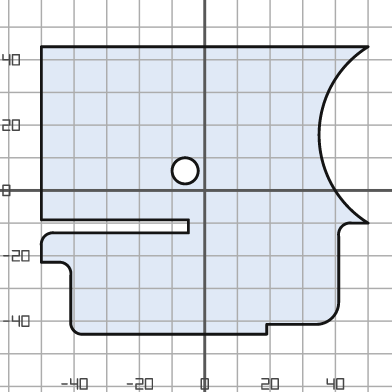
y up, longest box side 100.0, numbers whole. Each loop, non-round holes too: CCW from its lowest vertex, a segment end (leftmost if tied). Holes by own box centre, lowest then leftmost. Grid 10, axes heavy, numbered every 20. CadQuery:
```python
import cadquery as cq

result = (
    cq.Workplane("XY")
    .moveTo(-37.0, -44.0)
    .lineTo(19.0, -44.0)
    .lineTo(19.0, -41.0)
    .lineTo(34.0, -41.0)
    .threePointArc((39.0, -39.0), (41.0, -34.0))
    .lineTo(41.0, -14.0)
    .threePointArc((42.0, -11.0), (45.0, -10.0))
    .lineTo(50.0, -10.0)
    .threePointArc((35.0, 17.0), (50.0, 44.0))
    .lineTo(-50.0, 44.0)
    .lineTo(-50.0, -9.0)
    .lineTo(-5.0, -9.0)
    .lineTo(-5.0, -13.0)
    .lineTo(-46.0, -13.0)
    .threePointArc((-49.0, -14.0), (-50.0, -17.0))
    .lineTo(-50.0, -22.0)
    .lineTo(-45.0, -22.0)
    .threePointArc((-42.0, -23.0), (-41.0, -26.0))
    .lineTo(-41.0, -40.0)
    .threePointArc((-40.0, -43.0), (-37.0, -44.0))
    .close()
    .moveTo(-6.0, 6.0)
    .circle(4.0)
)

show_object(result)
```